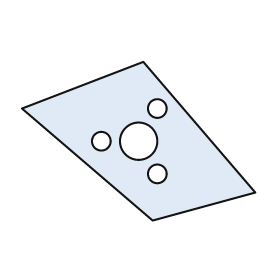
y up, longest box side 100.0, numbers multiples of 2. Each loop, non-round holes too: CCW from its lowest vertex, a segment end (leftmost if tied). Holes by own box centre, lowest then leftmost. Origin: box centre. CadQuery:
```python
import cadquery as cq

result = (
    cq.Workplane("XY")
    .moveTo(6.0, -34.0)
    .lineTo(50.0, -22.0)
    .lineTo(2.0, 34.0)
    .lineTo(-50.0, 14.0)
    .close()
    .moveTo(8.0, -14.0)
    .circle(4.0)
    .moveTo(-16.0, 0.0)
    .circle(4.0)
    .moveTo(0.0, 0.0)
    .circle(8.0)
    .moveTo(8.0, 14.0)
    .circle(4.0)
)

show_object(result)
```